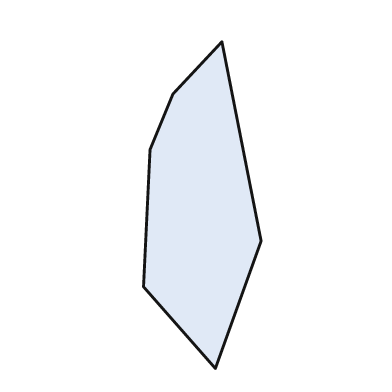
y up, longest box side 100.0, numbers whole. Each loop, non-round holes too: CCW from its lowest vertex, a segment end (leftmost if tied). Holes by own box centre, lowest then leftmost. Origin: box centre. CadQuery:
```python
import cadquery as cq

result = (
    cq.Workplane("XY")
    .moveTo(4.0, -50.0)
    .lineTo(18.0, -11.0)
    .lineTo(6.0, 50.0)
    .lineTo(-9.0, 34.0)
    .lineTo(-16.0, 17.0)
    .lineTo(-18.0, -25.0)
    .close()
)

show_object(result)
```